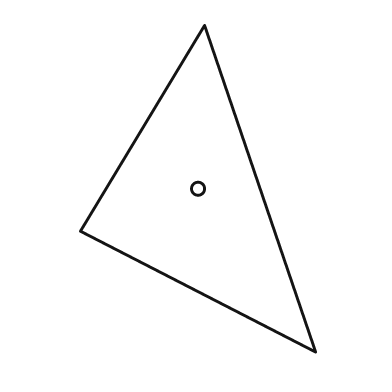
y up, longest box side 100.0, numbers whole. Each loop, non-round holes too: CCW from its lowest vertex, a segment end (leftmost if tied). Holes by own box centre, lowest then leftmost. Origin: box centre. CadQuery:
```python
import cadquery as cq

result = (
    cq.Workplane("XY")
    .moveTo(36.0, -50.0)
    .lineTo(2.0, 50.0)
    .lineTo(-36.0, -13.0)
    .close()
    .moveTo(0.0, 0.0)
    .circle(2.0)
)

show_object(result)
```